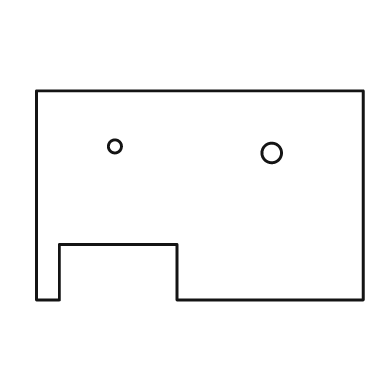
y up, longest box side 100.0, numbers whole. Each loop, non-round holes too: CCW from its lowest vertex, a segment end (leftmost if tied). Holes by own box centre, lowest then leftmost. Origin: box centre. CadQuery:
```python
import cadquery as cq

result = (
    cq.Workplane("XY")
    .moveTo(-50.0, -32.0)
    .lineTo(-43.0, -32.0)
    .lineTo(-43.0, -15.0)
    .lineTo(-7.0, -15.0)
    .lineTo(-7.0, -32.0)
    .lineTo(50.0, -32.0)
    .lineTo(50.0, 32.0)
    .lineTo(-50.0, 32.0)
    .close()
    .moveTo(22.0, 13.0)
    .circle(3.0)
    .moveTo(-26.0, 15.0)
    .circle(2.0)
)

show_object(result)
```